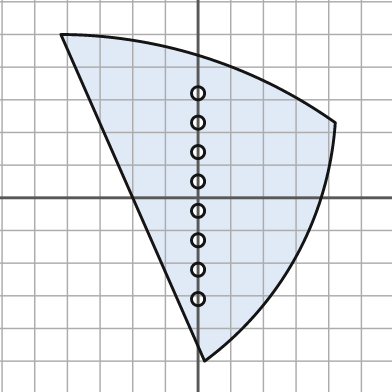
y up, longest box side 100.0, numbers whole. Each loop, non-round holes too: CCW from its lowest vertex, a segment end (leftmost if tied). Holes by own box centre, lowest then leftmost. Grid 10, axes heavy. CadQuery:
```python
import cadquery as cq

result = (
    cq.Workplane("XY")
    .moveTo(2.0, -50.0)
    .threePointArc((30.0, -18.0), (42.0, 23.0))
    .threePointArc((2.0, 43.0), (-42.0, 50.0))
    .close()
    .moveTo(0.0, -31.0)
    .circle(2.0)
    .moveTo(0.0, -22.0)
    .circle(2.0)
    .moveTo(0.0, -13.0)
    .circle(2.0)
    .moveTo(0.0, -4.0)
    .circle(2.0)
    .moveTo(0.0, 5.0)
    .circle(2.0)
    .moveTo(0.0, 14.0)
    .circle(2.0)
    .moveTo(0.0, 23.0)
    .circle(2.0)
    .moveTo(0.0, 32.0)
    .circle(2.0)
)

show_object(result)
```